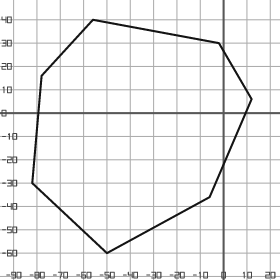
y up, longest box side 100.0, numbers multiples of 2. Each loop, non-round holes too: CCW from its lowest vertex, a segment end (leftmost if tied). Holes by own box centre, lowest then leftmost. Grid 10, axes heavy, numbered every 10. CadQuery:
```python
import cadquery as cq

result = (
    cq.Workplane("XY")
    .moveTo(-50.0, -60.0)
    .lineTo(-6.0, -36.0)
    .lineTo(12.0, 6.0)
    .lineTo(-2.0, 30.0)
    .lineTo(-56.0, 40.0)
    .lineTo(-78.0, 16.0)
    .lineTo(-82.0, -30.0)
    .close()
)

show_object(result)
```